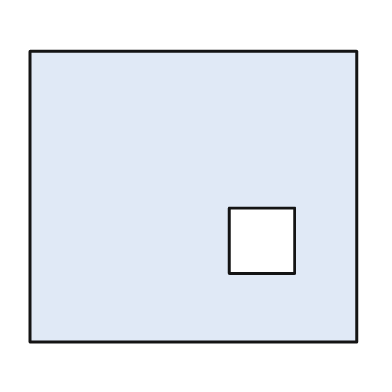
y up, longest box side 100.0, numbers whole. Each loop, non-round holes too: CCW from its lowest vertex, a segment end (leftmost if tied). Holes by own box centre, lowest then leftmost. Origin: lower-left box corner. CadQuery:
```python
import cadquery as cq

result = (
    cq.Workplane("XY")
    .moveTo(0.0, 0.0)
    .lineTo(100.0, 0.0)
    .lineTo(100.0, 89.0)
    .lineTo(0.0, 89.0)
    .close()
    .moveTo(61.0, 21.0)
    .lineTo(81.0, 21.0)
    .lineTo(81.0, 41.0)
    .lineTo(61.0, 41.0)
    .close()
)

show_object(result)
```